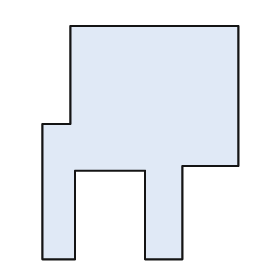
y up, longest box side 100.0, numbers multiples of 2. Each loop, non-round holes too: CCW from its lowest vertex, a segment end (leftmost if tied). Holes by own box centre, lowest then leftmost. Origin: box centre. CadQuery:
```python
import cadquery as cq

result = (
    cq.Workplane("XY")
    .moveTo(-42.0, -50.0)
    .lineTo(-28.0, -50.0)
    .lineTo(-28.0, -12.0)
    .lineTo(2.0, -12.0)
    .lineTo(2.0, -50.0)
    .lineTo(18.0, -50.0)
    .lineTo(18.0, -10.0)
    .lineTo(42.0, -10.0)
    .lineTo(42.0, 50.0)
    .lineTo(-30.0, 50.0)
    .lineTo(-30.0, 8.0)
    .lineTo(-42.0, 8.0)
    .close()
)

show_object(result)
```